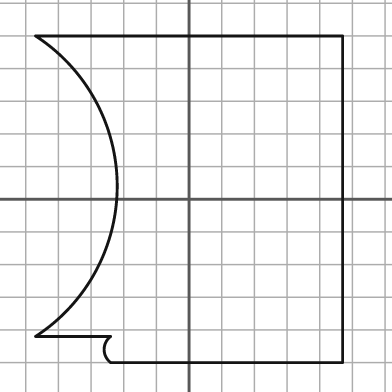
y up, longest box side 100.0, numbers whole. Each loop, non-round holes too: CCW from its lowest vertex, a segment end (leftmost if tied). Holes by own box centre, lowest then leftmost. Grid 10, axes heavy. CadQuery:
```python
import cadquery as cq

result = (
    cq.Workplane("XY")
    .moveTo(-24.0, -50.0)
    .lineTo(47.0, -50.0)
    .lineTo(47.0, 50.0)
    .lineTo(-47.0, 50.0)
    .threePointArc((-22.0, 4.0), (-47.0, -42.0))
    .lineTo(-24.0, -42.0)
    .threePointArc((-26.0, -46.0), (-24.0, -50.0))
    .close()
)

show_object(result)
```